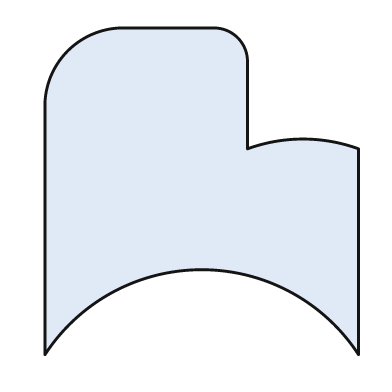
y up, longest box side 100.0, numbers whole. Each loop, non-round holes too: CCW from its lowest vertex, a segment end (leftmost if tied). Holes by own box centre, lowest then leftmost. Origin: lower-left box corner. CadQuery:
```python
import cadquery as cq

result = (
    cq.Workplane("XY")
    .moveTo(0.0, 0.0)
    .threePointArc((48.0, 26.0), (96.0, 0.0))
    .lineTo(96.0, 63.0)
    .threePointArc((79.0, 66.0), (62.0, 63.0))
    .lineTo(62.0, 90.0)
    .threePointArc((59.0, 97.0), (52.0, 100.0))
    .lineTo(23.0, 100.0)
    .threePointArc((7.0, 93.0), (0.0, 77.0))
    .close()
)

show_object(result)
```